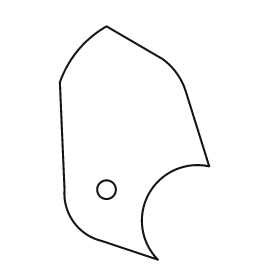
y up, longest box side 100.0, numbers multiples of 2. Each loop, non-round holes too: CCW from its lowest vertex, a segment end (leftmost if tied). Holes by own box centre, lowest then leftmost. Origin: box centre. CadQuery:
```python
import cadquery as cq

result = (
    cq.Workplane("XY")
    .moveTo(10.0, -50.0)
    .threePointArc((6.0, -22.0), (32.0, -10.0))
    .lineTo(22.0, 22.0)
    .threePointArc((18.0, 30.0), (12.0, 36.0))
    .lineTo(-12.0, 50.0)
    .threePointArc((-24.0, 40.0), (-32.0, 26.0))
    .lineTo(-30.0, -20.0)
    .threePointArc((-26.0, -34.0), (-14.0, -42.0))
    .close()
    .moveTo(-12.0, -20.0)
    .circle(4.0)
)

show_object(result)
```